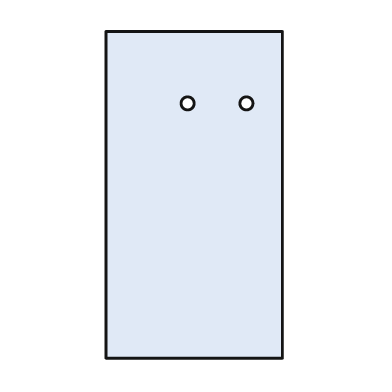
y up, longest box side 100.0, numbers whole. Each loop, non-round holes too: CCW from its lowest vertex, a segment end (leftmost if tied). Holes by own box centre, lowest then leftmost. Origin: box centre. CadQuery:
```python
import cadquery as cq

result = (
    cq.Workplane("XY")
    .moveTo(-27.0, -50.0)
    .lineTo(27.0, -50.0)
    .lineTo(27.0, 50.0)
    .lineTo(-27.0, 50.0)
    .close()
    .moveTo(-2.0, 28.0)
    .circle(2.0)
    .moveTo(16.0, 28.0)
    .circle(2.0)
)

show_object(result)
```